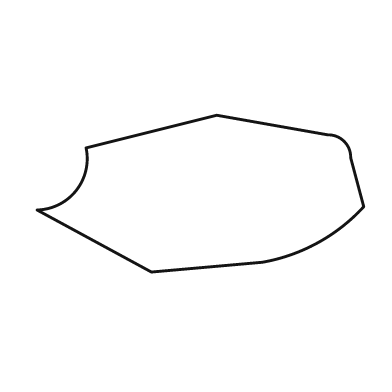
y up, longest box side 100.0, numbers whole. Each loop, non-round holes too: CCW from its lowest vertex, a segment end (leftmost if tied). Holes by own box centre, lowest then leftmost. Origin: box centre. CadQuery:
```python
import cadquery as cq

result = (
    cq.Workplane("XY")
    .moveTo(-15.0, -24.0)
    .lineTo(19.0, -21.0)
    .threePointArc((36.0, -15.0), (50.0, -4.0))
    .lineTo(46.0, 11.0)
    .threePointArc((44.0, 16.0), (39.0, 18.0))
    .lineTo(5.0, 24.0)
    .lineTo(-35.0, 14.0)
    .threePointArc((-38.0, 1.0), (-50.0, -5.0))
    .close()
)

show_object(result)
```